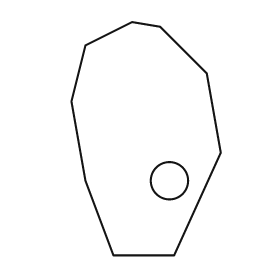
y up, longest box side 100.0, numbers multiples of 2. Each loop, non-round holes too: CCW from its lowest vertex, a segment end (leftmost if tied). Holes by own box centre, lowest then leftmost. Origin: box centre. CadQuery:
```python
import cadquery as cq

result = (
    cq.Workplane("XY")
    .moveTo(-14.0, -50.0)
    .lineTo(12.0, -50.0)
    .lineTo(32.0, -6.0)
    .lineTo(26.0, 28.0)
    .lineTo(6.0, 48.0)
    .lineTo(-6.0, 50.0)
    .lineTo(-26.0, 40.0)
    .lineTo(-32.0, 16.0)
    .lineTo(-26.0, -18.0)
    .close()
    .moveTo(10.0, -18.0)
    .circle(8.0)
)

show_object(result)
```